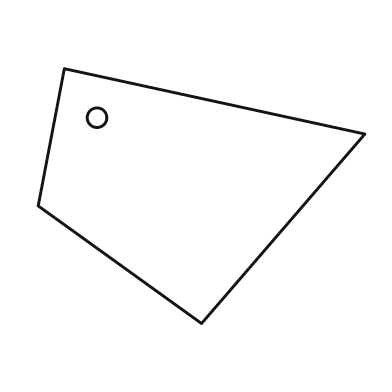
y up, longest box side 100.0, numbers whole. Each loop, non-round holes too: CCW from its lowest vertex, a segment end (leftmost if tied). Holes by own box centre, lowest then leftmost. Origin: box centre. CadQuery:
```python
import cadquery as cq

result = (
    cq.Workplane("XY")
    .moveTo(0.0, -39.0)
    .lineTo(50.0, 19.0)
    .lineTo(-42.0, 39.0)
    .lineTo(-50.0, -3.0)
    .close()
    .moveTo(-32.0, 24.0)
    .circle(3.0)
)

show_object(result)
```